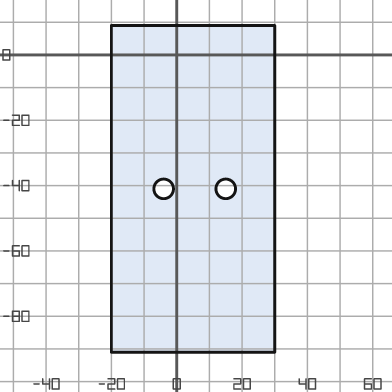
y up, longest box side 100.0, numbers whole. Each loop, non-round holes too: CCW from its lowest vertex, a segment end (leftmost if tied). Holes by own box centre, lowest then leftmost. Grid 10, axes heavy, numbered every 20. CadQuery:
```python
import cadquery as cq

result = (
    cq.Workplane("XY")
    .moveTo(-20.0, -91.0)
    .lineTo(30.0, -91.0)
    .lineTo(30.0, 9.0)
    .lineTo(-20.0, 9.0)
    .close()
    .moveTo(-4.0, -41.0)
    .circle(3.0)
    .moveTo(15.0, -41.0)
    .circle(3.0)
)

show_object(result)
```